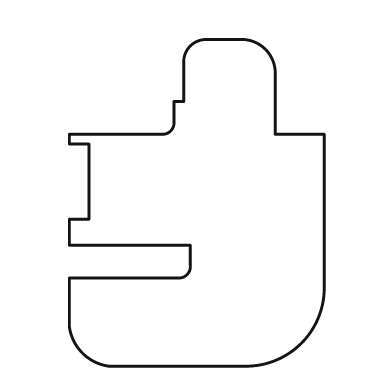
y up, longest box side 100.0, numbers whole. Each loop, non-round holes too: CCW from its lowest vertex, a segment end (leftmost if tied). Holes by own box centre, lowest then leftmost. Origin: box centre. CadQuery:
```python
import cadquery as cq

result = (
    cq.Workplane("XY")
    .moveTo(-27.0, -50.0)
    .lineTo(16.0, -50.0)
    .threePointArc((32.0, -43.0), (39.0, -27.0))
    .lineTo(39.0, 21.0)
    .lineTo(24.0, 21.0)
    .lineTo(24.0, 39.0)
    .threePointArc((21.0, 47.0), (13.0, 50.0))
    .lineTo(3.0, 50.0)
    .threePointArc((-2.0, 48.0), (-4.0, 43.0))
    .lineTo(-4.0, 31.0)
    .lineTo(-7.0, 31.0)
    .lineTo(-7.0, 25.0)
    .threePointArc((-8.0, 22.0), (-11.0, 21.0))
    .lineTo(-39.0, 21.0)
    .lineTo(-39.0, 18.0)
    .lineTo(-33.0, 18.0)
    .lineTo(-33.0, -5.0)
    .lineTo(-39.0, -5.0)
    .lineTo(-39.0, -13.0)
    .lineTo(-2.0, -13.0)
    .lineTo(-2.0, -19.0)
    .threePointArc((-3.0, -22.0), (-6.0, -23.0))
    .lineTo(-39.0, -23.0)
    .lineTo(-39.0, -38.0)
    .threePointArc((-35.0, -46.0), (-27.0, -50.0))
    .close()
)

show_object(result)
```